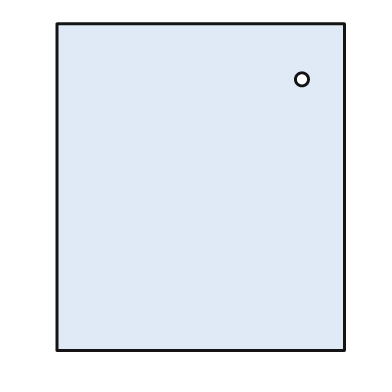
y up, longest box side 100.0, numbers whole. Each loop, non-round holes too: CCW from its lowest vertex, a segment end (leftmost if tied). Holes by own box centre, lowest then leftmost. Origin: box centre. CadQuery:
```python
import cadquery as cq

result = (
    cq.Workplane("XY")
    .moveTo(-44.0, -50.0)
    .lineTo(44.0, -50.0)
    .lineTo(44.0, 50.0)
    .lineTo(-44.0, 50.0)
    .close()
    .moveTo(31.0, 33.0)
    .circle(2.0)
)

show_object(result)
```